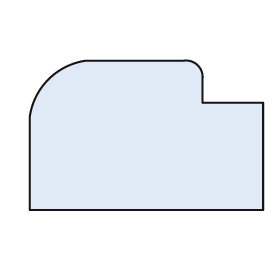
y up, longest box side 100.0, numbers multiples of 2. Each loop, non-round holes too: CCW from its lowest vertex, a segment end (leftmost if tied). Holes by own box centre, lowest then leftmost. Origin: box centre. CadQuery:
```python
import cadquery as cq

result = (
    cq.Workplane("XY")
    .moveTo(-50.0, -32.0)
    .lineTo(50.0, -32.0)
    .lineTo(50.0, 14.0)
    .lineTo(24.0, 14.0)
    .lineTo(24.0, 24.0)
    .threePointArc((22.0, 30.0), (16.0, 32.0))
    .lineTo(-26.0, 32.0)
    .threePointArc((-42.0, 24.0), (-50.0, 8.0))
    .close()
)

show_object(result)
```